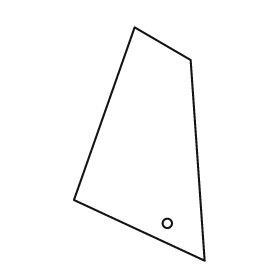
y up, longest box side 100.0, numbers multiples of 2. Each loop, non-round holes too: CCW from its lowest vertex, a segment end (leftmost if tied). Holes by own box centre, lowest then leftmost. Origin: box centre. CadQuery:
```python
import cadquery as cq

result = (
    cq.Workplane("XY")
    .moveTo(28.0, -50.0)
    .lineTo(22.0, 36.0)
    .lineTo(-2.0, 50.0)
    .lineTo(-28.0, -24.0)
    .close()
    .moveTo(12.0, -34.0)
    .circle(2.0)
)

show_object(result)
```